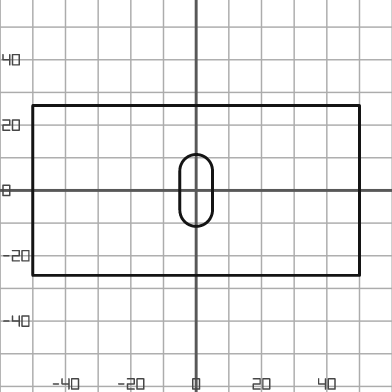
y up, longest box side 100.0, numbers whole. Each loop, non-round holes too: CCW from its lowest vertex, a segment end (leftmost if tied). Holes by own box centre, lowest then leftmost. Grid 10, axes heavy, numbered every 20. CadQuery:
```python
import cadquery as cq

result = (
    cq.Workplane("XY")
    .moveTo(-50.0, -26.0)
    .lineTo(50.0, -26.0)
    .lineTo(50.0, 26.0)
    .lineTo(-50.0, 26.0)
    .close()
    .moveTo(-5.0, -6.0)
    .threePointArc((0.0, -11.0), (5.0, -6.0))
    .lineTo(5.0, 6.0)
    .threePointArc((0.0, 11.0), (-5.0, 6.0))
    .close()
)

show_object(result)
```